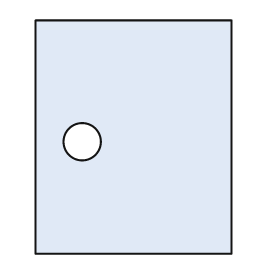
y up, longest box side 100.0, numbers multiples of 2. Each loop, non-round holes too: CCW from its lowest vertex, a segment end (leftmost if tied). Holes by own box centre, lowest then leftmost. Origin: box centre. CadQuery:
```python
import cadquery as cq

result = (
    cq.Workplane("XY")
    .moveTo(-42.0, -50.0)
    .lineTo(42.0, -50.0)
    .lineTo(42.0, 50.0)
    .lineTo(-42.0, 50.0)
    .close()
    .moveTo(-22.0, -2.0)
    .circle(8.0)
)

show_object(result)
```